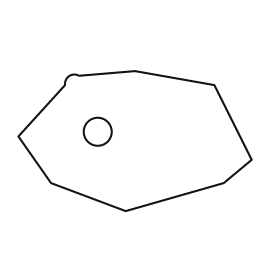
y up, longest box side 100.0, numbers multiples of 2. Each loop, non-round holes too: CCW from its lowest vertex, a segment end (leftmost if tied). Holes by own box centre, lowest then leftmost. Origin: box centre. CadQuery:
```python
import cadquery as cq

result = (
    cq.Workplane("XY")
    .moveTo(-4.0, -30.0)
    .lineTo(38.0, -18.0)
    .lineTo(50.0, -8.0)
    .lineTo(34.0, 24.0)
    .lineTo(0.0, 30.0)
    .lineTo(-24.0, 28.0)
    .threePointArc((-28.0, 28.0), (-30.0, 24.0))
    .lineTo(-50.0, 2.0)
    .lineTo(-36.0, -18.0)
    .close()
    .moveTo(-16.0, 4.0)
    .circle(6.0)
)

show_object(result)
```